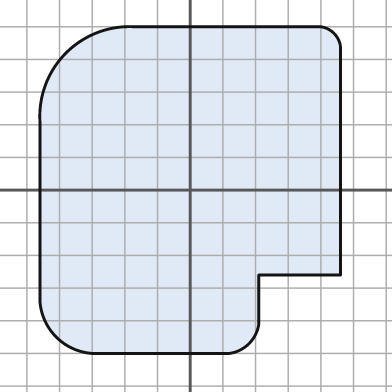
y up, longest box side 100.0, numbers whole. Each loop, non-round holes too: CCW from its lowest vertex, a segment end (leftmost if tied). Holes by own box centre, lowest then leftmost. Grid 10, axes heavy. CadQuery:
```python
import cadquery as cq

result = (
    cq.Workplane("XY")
    .moveTo(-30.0, -50.0)
    .lineTo(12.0, -50.0)
    .threePointArc((18.0, -47.0), (21.0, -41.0))
    .lineTo(21.0, -26.0)
    .lineTo(46.0, -26.0)
    .lineTo(46.0, 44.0)
    .threePointArc((44.0, 48.0), (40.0, 50.0))
    .lineTo(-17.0, 50.0)
    .threePointArc((-38.0, 42.0), (-46.0, 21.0))
    .lineTo(-46.0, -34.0)
    .threePointArc((-41.0, -45.0), (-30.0, -50.0))
    .close()
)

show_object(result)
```